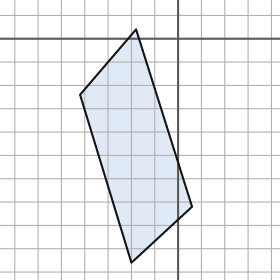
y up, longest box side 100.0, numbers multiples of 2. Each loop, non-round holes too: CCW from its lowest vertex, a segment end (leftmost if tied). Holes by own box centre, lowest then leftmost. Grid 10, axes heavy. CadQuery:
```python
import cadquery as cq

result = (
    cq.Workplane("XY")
    .moveTo(-20.0, -96.0)
    .lineTo(6.0, -72.0)
    .lineTo(-18.0, 4.0)
    .lineTo(-42.0, -24.0)
    .close()
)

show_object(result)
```